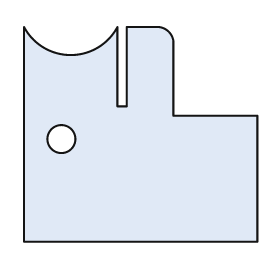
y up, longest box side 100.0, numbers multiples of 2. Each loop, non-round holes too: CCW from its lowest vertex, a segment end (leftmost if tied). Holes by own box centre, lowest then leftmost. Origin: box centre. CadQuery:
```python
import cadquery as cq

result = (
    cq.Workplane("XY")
    .moveTo(-50.0, -46.0)
    .lineTo(50.0, -46.0)
    .lineTo(50.0, 8.0)
    .lineTo(14.0, 8.0)
    .lineTo(14.0, 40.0)
    .threePointArc((12.0, 44.0), (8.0, 46.0))
    .lineTo(-6.0, 46.0)
    .lineTo(-6.0, 12.0)
    .lineTo(-10.0, 12.0)
    .lineTo(-10.0, 46.0)
    .threePointArc((-30.0, 34.0), (-50.0, 46.0))
    .close()
    .moveTo(-34.0, -2.0)
    .circle(6.0)
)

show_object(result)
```